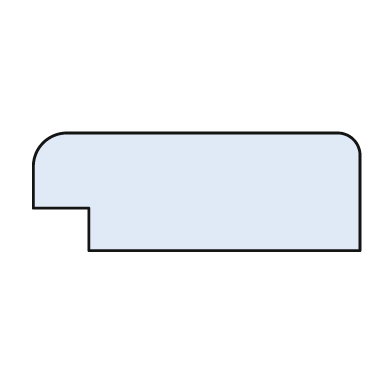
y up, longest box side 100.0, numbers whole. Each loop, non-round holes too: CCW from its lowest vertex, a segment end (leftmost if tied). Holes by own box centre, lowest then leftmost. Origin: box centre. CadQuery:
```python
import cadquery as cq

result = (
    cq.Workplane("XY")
    .moveTo(-33.0, -18.0)
    .lineTo(50.0, -18.0)
    .lineTo(50.0, 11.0)
    .threePointArc((48.0, 16.0), (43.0, 18.0))
    .lineTo(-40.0, 18.0)
    .threePointArc((-47.0, 15.0), (-50.0, 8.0))
    .lineTo(-50.0, -5.0)
    .lineTo(-33.0, -5.0)
    .close()
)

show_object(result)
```